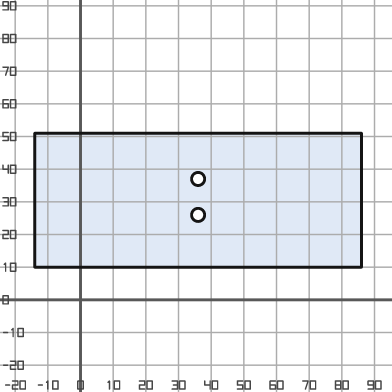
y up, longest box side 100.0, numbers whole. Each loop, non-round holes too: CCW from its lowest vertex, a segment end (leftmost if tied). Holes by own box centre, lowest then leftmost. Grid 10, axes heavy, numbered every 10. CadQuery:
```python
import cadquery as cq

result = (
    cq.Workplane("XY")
    .moveTo(-14.0, 10.0)
    .lineTo(86.0, 10.0)
    .lineTo(86.0, 51.0)
    .lineTo(-14.0, 51.0)
    .close()
    .moveTo(36.0, 26.0)
    .circle(2.0)
    .moveTo(36.0, 37.0)
    .circle(2.0)
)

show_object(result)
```